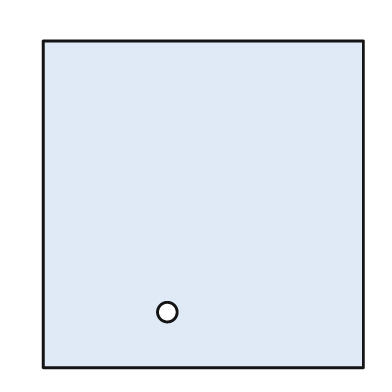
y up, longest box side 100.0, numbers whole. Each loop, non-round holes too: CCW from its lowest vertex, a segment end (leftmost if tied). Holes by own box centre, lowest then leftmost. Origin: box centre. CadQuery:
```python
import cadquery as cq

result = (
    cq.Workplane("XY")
    .moveTo(-49.0, -50.0)
    .lineTo(49.0, -50.0)
    .lineTo(49.0, 50.0)
    .lineTo(-49.0, 50.0)
    .close()
    .moveTo(-11.0, -33.0)
    .circle(3.0)
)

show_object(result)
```